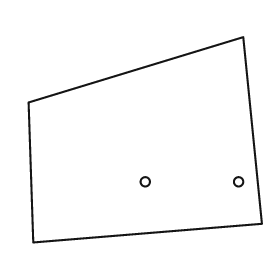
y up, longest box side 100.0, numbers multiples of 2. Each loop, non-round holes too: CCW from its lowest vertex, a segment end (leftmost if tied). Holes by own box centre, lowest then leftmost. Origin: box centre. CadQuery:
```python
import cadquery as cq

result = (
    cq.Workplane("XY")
    .moveTo(-48.0, -44.0)
    .lineTo(50.0, -36.0)
    .lineTo(42.0, 44.0)
    .lineTo(-50.0, 16.0)
    .close()
    .moveTo(0.0, -18.0)
    .circle(2.0)
    .moveTo(40.0, -18.0)
    .circle(2.0)
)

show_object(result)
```